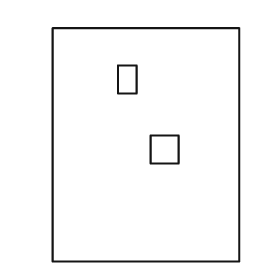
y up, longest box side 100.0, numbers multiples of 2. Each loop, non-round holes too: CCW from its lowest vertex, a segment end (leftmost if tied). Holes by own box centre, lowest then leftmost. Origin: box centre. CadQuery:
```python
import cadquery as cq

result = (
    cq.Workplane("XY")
    .moveTo(-40.0, -50.0)
    .lineTo(40.0, -50.0)
    .lineTo(40.0, 50.0)
    .lineTo(-40.0, 50.0)
    .close()
    .moveTo(2.0, -8.0)
    .lineTo(14.0, -8.0)
    .lineTo(14.0, 4.0)
    .lineTo(2.0, 4.0)
    .close()
    .moveTo(-12.0, 22.0)
    .lineTo(-4.0, 22.0)
    .lineTo(-4.0, 34.0)
    .lineTo(-12.0, 34.0)
    .close()
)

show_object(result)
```